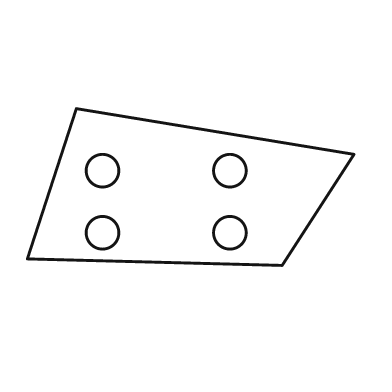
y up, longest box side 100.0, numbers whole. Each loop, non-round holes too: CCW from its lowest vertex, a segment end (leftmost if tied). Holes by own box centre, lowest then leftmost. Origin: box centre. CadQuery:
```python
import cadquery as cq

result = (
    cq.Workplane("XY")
    .moveTo(28.0, -24.0)
    .lineTo(50.0, 10.0)
    .lineTo(-35.0, 24.0)
    .lineTo(-50.0, -22.0)
    .close()
    .moveTo(-27.0, -14.0)
    .circle(5.0)
    .moveTo(12.0, -14.0)
    .circle(5.0)
    .moveTo(-27.0, 5.0)
    .circle(5.0)
    .moveTo(12.0, 5.0)
    .circle(5.0)
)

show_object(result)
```